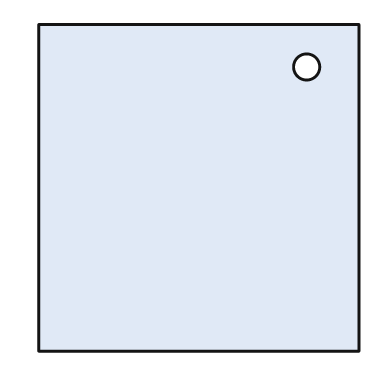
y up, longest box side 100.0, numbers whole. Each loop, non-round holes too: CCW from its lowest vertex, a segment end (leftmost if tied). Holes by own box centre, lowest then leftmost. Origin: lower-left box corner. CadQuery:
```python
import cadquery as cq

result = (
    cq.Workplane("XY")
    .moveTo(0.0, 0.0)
    .lineTo(98.0, 0.0)
    .lineTo(98.0, 100.0)
    .lineTo(0.0, 100.0)
    .close()
    .moveTo(82.0, 87.0)
    .circle(4.0)
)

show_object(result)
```